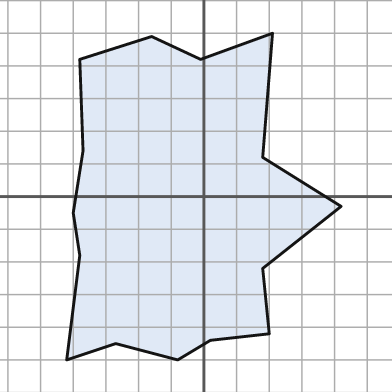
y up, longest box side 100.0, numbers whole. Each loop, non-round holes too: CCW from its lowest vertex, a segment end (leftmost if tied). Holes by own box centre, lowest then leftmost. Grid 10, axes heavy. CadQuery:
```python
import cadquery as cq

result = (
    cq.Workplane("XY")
    .moveTo(-42.0, -50.0)
    .lineTo(-27.0, -45.0)
    .lineTo(-8.0, -50.0)
    .lineTo(2.0, -44.0)
    .lineTo(20.0, -42.0)
    .lineTo(18.0, -22.0)
    .lineTo(42.0, -3.0)
    .lineTo(18.0, 12.0)
    .lineTo(21.0, 50.0)
    .lineTo(-1.0, 42.0)
    .lineTo(-16.0, 49.0)
    .lineTo(-38.0, 42.0)
    .lineTo(-37.0, 14.0)
    .lineTo(-40.0, -5.0)
    .lineTo(-38.0, -18.0)
    .close()
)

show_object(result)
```